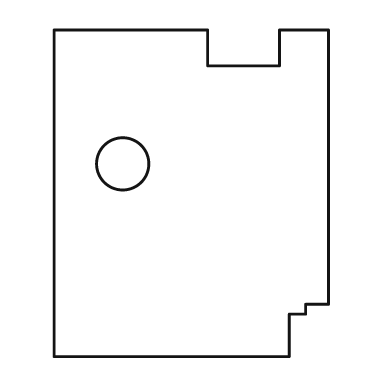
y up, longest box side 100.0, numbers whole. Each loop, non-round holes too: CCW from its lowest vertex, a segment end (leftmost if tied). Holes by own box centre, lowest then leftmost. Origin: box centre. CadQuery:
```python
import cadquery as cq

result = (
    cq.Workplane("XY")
    .moveTo(-42.0, -50.0)
    .lineTo(30.0, -50.0)
    .lineTo(30.0, -37.0)
    .lineTo(35.0, -37.0)
    .lineTo(35.0, -34.0)
    .lineTo(42.0, -34.0)
    .lineTo(42.0, 50.0)
    .lineTo(27.0, 50.0)
    .lineTo(27.0, 39.0)
    .lineTo(5.0, 39.0)
    .lineTo(5.0, 50.0)
    .lineTo(-42.0, 50.0)
    .close()
    .moveTo(-21.0, 9.0)
    .circle(8.0)
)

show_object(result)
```